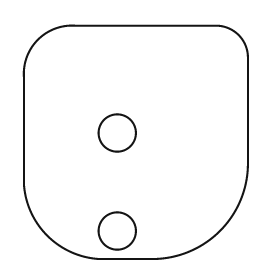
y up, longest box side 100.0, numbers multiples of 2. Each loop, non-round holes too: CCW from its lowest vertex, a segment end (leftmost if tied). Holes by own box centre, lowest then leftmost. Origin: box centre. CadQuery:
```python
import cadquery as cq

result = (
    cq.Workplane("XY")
    .moveTo(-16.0, -50.0)
    .lineTo(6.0, -50.0)
    .threePointArc((36.0, -38.0), (48.0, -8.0))
    .lineTo(48.0, 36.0)
    .threePointArc((44.0, 46.0), (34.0, 50.0))
    .lineTo(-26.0, 50.0)
    .threePointArc((-42.0, 44.0), (-48.0, 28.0))
    .lineTo(-48.0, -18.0)
    .threePointArc((-38.0, -40.0), (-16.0, -50.0))
    .close()
    .moveTo(-8.0, -38.0)
    .circle(8.0)
    .moveTo(-8.0, 4.0)
    .circle(8.0)
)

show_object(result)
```